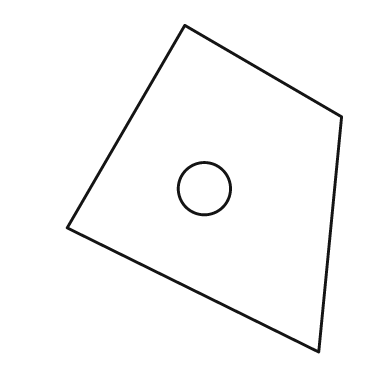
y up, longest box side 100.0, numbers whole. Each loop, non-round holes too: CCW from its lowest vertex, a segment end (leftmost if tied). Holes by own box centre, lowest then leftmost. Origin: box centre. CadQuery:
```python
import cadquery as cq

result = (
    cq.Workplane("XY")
    .moveTo(35.0, -50.0)
    .lineTo(42.0, 22.0)
    .lineTo(-6.0, 50.0)
    .lineTo(-42.0, -12.0)
    .close()
    .moveTo(0.0, 0.0)
    .circle(8.0)
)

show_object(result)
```